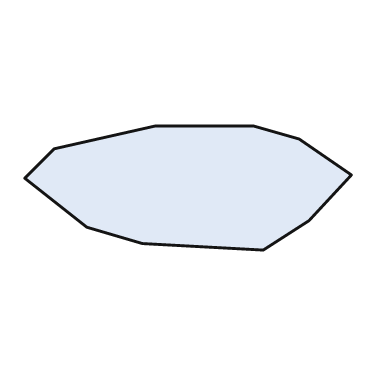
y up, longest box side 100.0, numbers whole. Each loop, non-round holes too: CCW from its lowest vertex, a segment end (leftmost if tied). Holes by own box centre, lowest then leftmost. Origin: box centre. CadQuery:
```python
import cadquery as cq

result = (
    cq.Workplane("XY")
    .moveTo(23.0, -19.0)
    .lineTo(37.0, -10.0)
    .lineTo(50.0, 4.0)
    .lineTo(34.0, 15.0)
    .lineTo(20.0, 19.0)
    .lineTo(-10.0, 19.0)
    .lineTo(-41.0, 12.0)
    .lineTo(-50.0, 3.0)
    .lineTo(-31.0, -12.0)
    .lineTo(-14.0, -17.0)
    .close()
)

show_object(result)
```